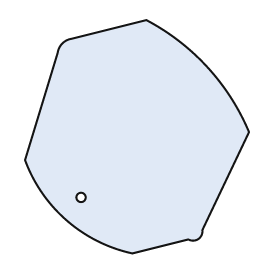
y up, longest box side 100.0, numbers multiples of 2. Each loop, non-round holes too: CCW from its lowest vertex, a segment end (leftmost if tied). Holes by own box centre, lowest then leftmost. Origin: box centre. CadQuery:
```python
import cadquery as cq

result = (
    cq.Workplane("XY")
    .moveTo(-2.0, -50.0)
    .lineTo(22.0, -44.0)
    .threePointArc((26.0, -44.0), (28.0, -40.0))
    .lineTo(48.0, 2.0)
    .threePointArc((30.0, 30.0), (4.0, 50.0))
    .lineTo(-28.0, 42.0)
    .threePointArc((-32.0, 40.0), (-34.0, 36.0))
    .lineTo(-48.0, -10.0)
    .threePointArc((-30.0, -36.0), (-2.0, -50.0))
    .close()
    .moveTo(-24.0, -26.0)
    .circle(2.0)
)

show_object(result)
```